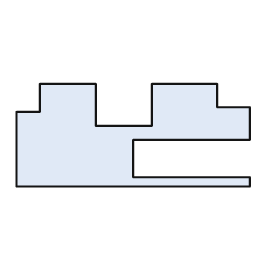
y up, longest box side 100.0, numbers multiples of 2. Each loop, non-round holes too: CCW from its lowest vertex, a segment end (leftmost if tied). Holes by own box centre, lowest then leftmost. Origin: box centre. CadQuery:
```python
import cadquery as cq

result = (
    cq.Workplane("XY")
    .moveTo(-50.0, -22.0)
    .lineTo(50.0, -22.0)
    .lineTo(50.0, -18.0)
    .lineTo(0.0, -18.0)
    .lineTo(0.0, -2.0)
    .lineTo(50.0, -2.0)
    .lineTo(50.0, 12.0)
    .lineTo(36.0, 12.0)
    .lineTo(36.0, 22.0)
    .lineTo(8.0, 22.0)
    .lineTo(8.0, 4.0)
    .lineTo(-16.0, 4.0)
    .lineTo(-16.0, 22.0)
    .lineTo(-40.0, 22.0)
    .lineTo(-40.0, 10.0)
    .lineTo(-50.0, 10.0)
    .close()
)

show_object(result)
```